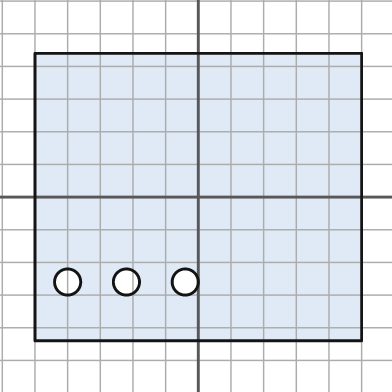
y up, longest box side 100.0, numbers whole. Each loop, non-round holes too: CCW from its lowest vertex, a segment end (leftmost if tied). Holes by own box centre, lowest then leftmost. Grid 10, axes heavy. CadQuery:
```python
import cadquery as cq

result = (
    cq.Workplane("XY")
    .moveTo(-50.0, -44.0)
    .lineTo(50.0, -44.0)
    .lineTo(50.0, 44.0)
    .lineTo(-50.0, 44.0)
    .close()
    .moveTo(-40.0, -26.0)
    .circle(4.0)
    .moveTo(-22.0, -26.0)
    .circle(4.0)
    .moveTo(-4.0, -26.0)
    .circle(4.0)
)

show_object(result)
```